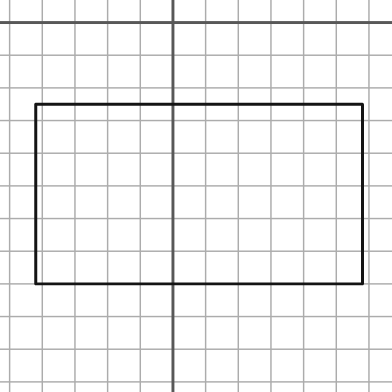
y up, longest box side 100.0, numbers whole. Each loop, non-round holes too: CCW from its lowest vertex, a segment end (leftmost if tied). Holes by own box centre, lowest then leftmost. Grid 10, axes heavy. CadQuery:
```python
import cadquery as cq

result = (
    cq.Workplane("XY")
    .moveTo(-42.0, -80.0)
    .lineTo(58.0, -80.0)
    .lineTo(58.0, -25.0)
    .lineTo(-42.0, -25.0)
    .close()
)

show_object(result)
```